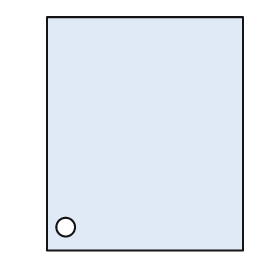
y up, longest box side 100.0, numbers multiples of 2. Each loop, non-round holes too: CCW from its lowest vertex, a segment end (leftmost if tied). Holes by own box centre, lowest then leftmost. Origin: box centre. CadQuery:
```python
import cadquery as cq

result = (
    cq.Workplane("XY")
    .moveTo(-42.0, -50.0)
    .lineTo(42.0, -50.0)
    .lineTo(42.0, 50.0)
    .lineTo(-42.0, 50.0)
    .close()
    .moveTo(-34.0, -40.0)
    .circle(4.0)
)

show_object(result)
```